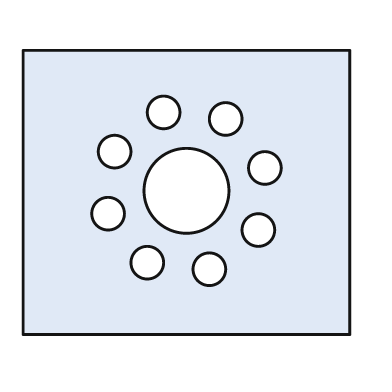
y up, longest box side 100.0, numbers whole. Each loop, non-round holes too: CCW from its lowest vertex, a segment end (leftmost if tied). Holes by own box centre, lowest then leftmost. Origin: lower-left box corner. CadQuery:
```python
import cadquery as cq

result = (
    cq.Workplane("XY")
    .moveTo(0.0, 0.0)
    .lineTo(100.0, 0.0)
    .lineTo(100.0, 87.0)
    .lineTo(0.0, 87.0)
    .close()
    .moveTo(57.0, 20.0)
    .circle(5.0)
    .moveTo(38.0, 22.0)
    .circle(5.0)
    .moveTo(72.0, 32.0)
    .circle(5.0)
    .moveTo(26.0, 37.0)
    .circle(5.0)
    .moveTo(50.0, 44.0)
    .circle(13.0)
    .moveTo(74.0, 51.0)
    .circle(5.0)
    .moveTo(28.0, 56.0)
    .circle(5.0)
    .moveTo(62.0, 66.0)
    .circle(5.0)
    .moveTo(43.0, 68.0)
    .circle(5.0)
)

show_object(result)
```